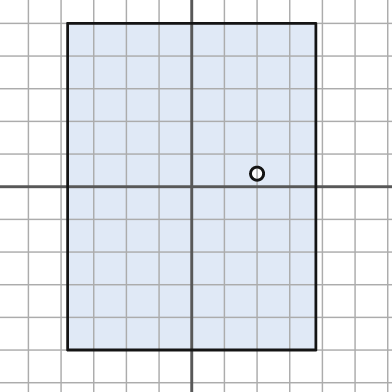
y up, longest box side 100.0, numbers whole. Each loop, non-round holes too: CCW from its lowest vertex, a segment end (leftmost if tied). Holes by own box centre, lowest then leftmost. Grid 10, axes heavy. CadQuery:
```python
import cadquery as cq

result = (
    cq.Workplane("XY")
    .moveTo(-38.0, -50.0)
    .lineTo(38.0, -50.0)
    .lineTo(38.0, 50.0)
    .lineTo(-38.0, 50.0)
    .close()
    .moveTo(20.0, 4.0)
    .circle(2.0)
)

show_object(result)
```